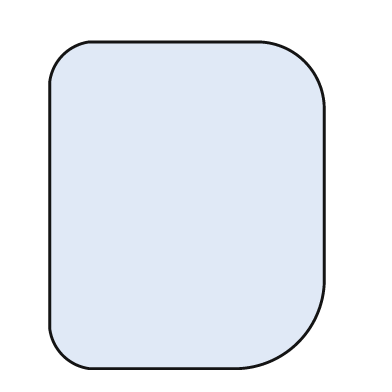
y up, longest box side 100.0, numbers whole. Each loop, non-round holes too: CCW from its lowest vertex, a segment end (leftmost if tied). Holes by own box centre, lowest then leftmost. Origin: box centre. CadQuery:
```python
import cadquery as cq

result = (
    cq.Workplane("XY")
    .moveTo(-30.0, -50.0)
    .lineTo(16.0, -50.0)
    .threePointArc((34.0, -42.0), (42.0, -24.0))
    .lineTo(42.0, 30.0)
    .threePointArc((36.0, 44.0), (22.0, 50.0))
    .lineTo(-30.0, 50.0)
    .threePointArc((-38.0, 46.0), (-42.0, 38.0))
    .lineTo(-42.0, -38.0)
    .threePointArc((-38.0, -46.0), (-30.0, -50.0))
    .close()
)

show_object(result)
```